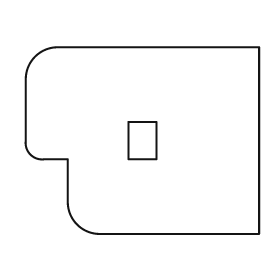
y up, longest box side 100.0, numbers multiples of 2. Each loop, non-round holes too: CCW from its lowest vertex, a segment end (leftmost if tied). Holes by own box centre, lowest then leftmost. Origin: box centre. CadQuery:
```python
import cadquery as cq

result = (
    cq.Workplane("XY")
    .moveTo(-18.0, -40.0)
    .lineTo(50.0, -40.0)
    .lineTo(50.0, 40.0)
    .lineTo(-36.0, 40.0)
    .threePointArc((-46.0, 36.0), (-50.0, 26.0))
    .lineTo(-50.0, 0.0)
    .threePointArc((-48.0, -6.0), (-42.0, -8.0))
    .lineTo(-32.0, -8.0)
    .lineTo(-32.0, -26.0)
    .threePointArc((-28.0, -36.0), (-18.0, -40.0))
    .close()
    .moveTo(-6.0, -8.0)
    .lineTo(6.0, -8.0)
    .lineTo(6.0, 8.0)
    .lineTo(-6.0, 8.0)
    .close()
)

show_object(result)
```